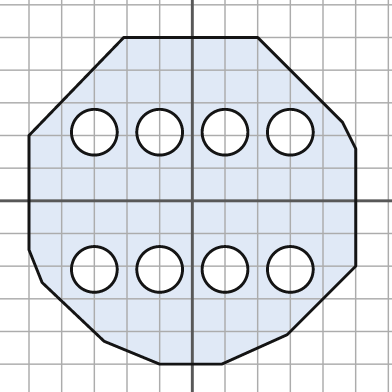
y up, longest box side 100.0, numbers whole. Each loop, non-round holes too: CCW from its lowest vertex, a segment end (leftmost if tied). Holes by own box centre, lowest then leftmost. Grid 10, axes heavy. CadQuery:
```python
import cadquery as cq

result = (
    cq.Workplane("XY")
    .moveTo(-10.0, -50.0)
    .lineTo(9.0, -50.0)
    .lineTo(29.0, -41.0)
    .lineTo(50.0, -20.0)
    .lineTo(50.0, 16.0)
    .lineTo(46.0, 24.0)
    .lineTo(20.0, 50.0)
    .lineTo(-21.0, 50.0)
    .lineTo(-50.0, 20.0)
    .lineTo(-50.0, -15.0)
    .lineTo(-46.0, -25.0)
    .lineTo(-27.0, -43.0)
    .close()
    .moveTo(-30.0, -21.0)
    .circle(7.0)
    .moveTo(-10.0, -21.0)
    .circle(7.0)
    .moveTo(10.0, -21.0)
    .circle(7.0)
    .moveTo(30.0, -21.0)
    .circle(7.0)
    .moveTo(-30.0, 21.0)
    .circle(7.0)
    .moveTo(-10.0, 21.0)
    .circle(7.0)
    .moveTo(10.0, 21.0)
    .circle(7.0)
    .moveTo(30.0, 21.0)
    .circle(7.0)
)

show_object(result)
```